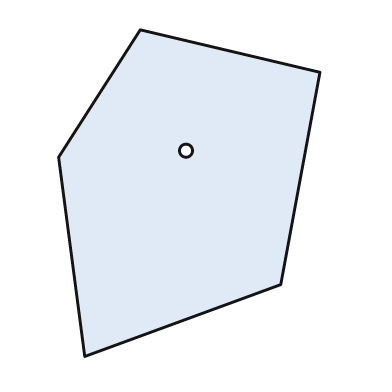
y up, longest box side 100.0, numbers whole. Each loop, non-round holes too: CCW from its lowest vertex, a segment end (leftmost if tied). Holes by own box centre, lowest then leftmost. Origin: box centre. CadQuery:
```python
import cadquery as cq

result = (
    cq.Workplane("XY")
    .moveTo(-32.0, -50.0)
    .lineTo(28.0, -28.0)
    .lineTo(40.0, 37.0)
    .lineTo(-15.0, 50.0)
    .lineTo(-40.0, 11.0)
    .close()
    .moveTo(-1.0, 13.0)
    .circle(2.0)
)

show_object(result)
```